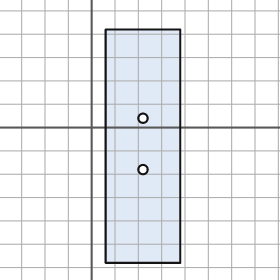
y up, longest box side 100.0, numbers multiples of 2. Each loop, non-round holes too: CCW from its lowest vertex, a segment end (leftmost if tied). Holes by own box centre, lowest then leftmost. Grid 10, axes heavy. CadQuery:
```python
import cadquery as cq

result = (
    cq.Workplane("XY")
    .moveTo(6.0, -58.0)
    .lineTo(38.0, -58.0)
    .lineTo(38.0, 42.0)
    .lineTo(6.0, 42.0)
    .close()
    .moveTo(22.0, -18.0)
    .circle(2.0)
    .moveTo(22.0, 4.0)
    .circle(2.0)
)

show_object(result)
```